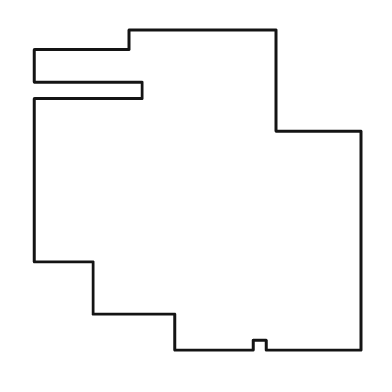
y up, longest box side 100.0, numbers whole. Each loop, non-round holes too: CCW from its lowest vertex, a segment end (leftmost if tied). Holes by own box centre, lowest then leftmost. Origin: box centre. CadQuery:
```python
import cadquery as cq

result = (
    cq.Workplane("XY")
    .moveTo(-7.0, -49.0)
    .lineTo(17.0, -49.0)
    .lineTo(17.0, -46.0)
    .lineTo(21.0, -46.0)
    .lineTo(21.0, -49.0)
    .lineTo(50.0, -49.0)
    .lineTo(50.0, 18.0)
    .lineTo(24.0, 18.0)
    .lineTo(24.0, 49.0)
    .lineTo(-21.0, 49.0)
    .lineTo(-21.0, 43.0)
    .lineTo(-50.0, 43.0)
    .lineTo(-50.0, 33.0)
    .lineTo(-17.0, 33.0)
    .lineTo(-17.0, 28.0)
    .lineTo(-50.0, 28.0)
    .lineTo(-50.0, -22.0)
    .lineTo(-32.0, -22.0)
    .lineTo(-32.0, -38.0)
    .lineTo(-7.0, -38.0)
    .close()
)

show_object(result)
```